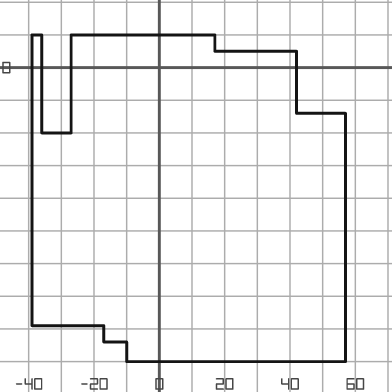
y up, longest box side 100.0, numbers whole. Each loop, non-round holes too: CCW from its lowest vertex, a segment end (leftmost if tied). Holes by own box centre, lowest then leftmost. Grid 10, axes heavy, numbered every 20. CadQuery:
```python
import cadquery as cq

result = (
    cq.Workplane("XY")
    .moveTo(-10.0, -90.0)
    .lineTo(57.0, -90.0)
    .lineTo(57.0, -14.0)
    .lineTo(42.0, -14.0)
    .lineTo(42.0, 5.0)
    .lineTo(17.0, 5.0)
    .lineTo(17.0, 10.0)
    .lineTo(-27.0, 10.0)
    .lineTo(-27.0, -20.0)
    .lineTo(-36.0, -20.0)
    .lineTo(-36.0, 10.0)
    .lineTo(-39.0, 10.0)
    .lineTo(-39.0, -79.0)
    .lineTo(-17.0, -79.0)
    .lineTo(-17.0, -84.0)
    .lineTo(-10.0, -84.0)
    .close()
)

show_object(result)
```